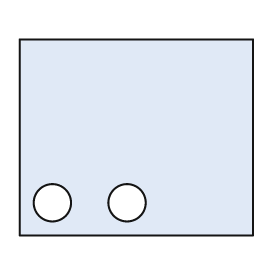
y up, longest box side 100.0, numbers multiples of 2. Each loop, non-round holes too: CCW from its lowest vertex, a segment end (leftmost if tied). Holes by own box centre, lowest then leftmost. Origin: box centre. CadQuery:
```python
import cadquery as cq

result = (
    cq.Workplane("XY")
    .moveTo(-50.0, -42.0)
    .lineTo(50.0, -42.0)
    .lineTo(50.0, 42.0)
    .lineTo(-50.0, 42.0)
    .close()
    .moveTo(-36.0, -28.0)
    .circle(8.0)
    .moveTo(-4.0, -28.0)
    .circle(8.0)
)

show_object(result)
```